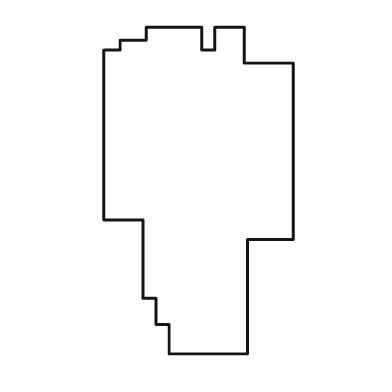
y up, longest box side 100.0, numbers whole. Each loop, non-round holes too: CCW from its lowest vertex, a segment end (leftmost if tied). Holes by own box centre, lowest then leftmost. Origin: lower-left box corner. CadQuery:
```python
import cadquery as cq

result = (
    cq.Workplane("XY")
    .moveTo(20.0, 0.0)
    .lineTo(44.0, 0.0)
    .lineTo(44.0, 35.0)
    .lineTo(58.0, 35.0)
    .lineTo(58.0, 89.0)
    .lineTo(43.0, 89.0)
    .lineTo(43.0, 100.0)
    .lineTo(34.0, 100.0)
    .lineTo(34.0, 93.0)
    .lineTo(30.0, 93.0)
    .lineTo(30.0, 100.0)
    .lineTo(13.0, 100.0)
    .lineTo(13.0, 96.0)
    .lineTo(5.0, 96.0)
    .lineTo(5.0, 93.0)
    .lineTo(0.0, 93.0)
    .lineTo(0.0, 41.0)
    .lineTo(12.0, 41.0)
    .lineTo(12.0, 17.0)
    .lineTo(16.0, 17.0)
    .lineTo(16.0, 9.0)
    .lineTo(20.0, 9.0)
    .close()
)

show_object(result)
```